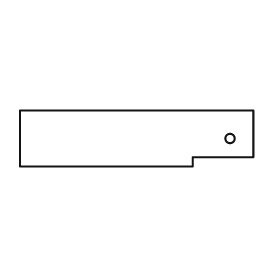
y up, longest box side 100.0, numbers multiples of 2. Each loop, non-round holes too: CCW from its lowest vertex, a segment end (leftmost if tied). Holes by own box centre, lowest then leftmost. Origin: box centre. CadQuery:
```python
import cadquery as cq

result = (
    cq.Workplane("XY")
    .moveTo(-50.0, -12.0)
    .lineTo(24.0, -12.0)
    .lineTo(24.0, -8.0)
    .lineTo(50.0, -8.0)
    .lineTo(50.0, 12.0)
    .lineTo(-50.0, 12.0)
    .close()
    .moveTo(40.0, 0.0)
    .circle(2.0)
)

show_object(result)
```